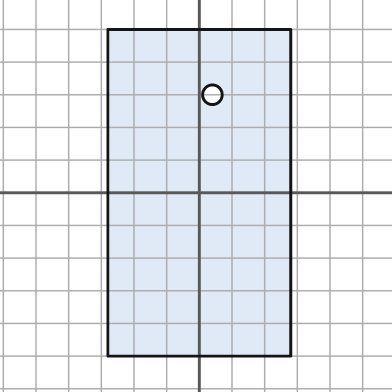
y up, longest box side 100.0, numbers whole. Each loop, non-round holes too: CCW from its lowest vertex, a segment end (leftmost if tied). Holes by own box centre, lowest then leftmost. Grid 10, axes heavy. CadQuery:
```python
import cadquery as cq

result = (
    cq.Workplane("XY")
    .moveTo(-28.0, -50.0)
    .lineTo(28.0, -50.0)
    .lineTo(28.0, 50.0)
    .lineTo(-28.0, 50.0)
    .close()
    .moveTo(4.0, 30.0)
    .circle(3.0)
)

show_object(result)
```